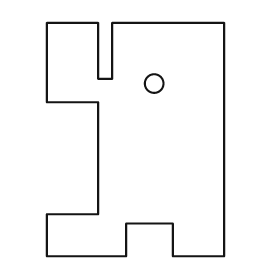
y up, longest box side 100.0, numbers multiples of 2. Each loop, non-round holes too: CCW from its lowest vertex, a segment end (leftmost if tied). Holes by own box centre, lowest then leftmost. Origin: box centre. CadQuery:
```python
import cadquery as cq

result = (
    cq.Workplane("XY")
    .moveTo(-38.0, -50.0)
    .lineTo(-4.0, -50.0)
    .lineTo(-4.0, -36.0)
    .lineTo(16.0, -36.0)
    .lineTo(16.0, -50.0)
    .lineTo(38.0, -50.0)
    .lineTo(38.0, 50.0)
    .lineTo(-10.0, 50.0)
    .lineTo(-10.0, 26.0)
    .lineTo(-16.0, 26.0)
    .lineTo(-16.0, 50.0)
    .lineTo(-38.0, 50.0)
    .lineTo(-38.0, 16.0)
    .lineTo(-16.0, 16.0)
    .lineTo(-16.0, -32.0)
    .lineTo(-38.0, -32.0)
    .close()
    .moveTo(8.0, 24.0)
    .circle(4.0)
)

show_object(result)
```